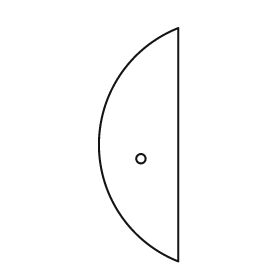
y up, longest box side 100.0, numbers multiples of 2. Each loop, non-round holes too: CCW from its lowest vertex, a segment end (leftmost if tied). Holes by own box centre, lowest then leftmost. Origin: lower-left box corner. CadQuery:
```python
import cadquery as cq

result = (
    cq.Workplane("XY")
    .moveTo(34.0, 0.0)
    .lineTo(34.0, 100.0)
    .threePointArc((0.0, 50.0), (34.0, 0.0))
    .close()
    .moveTo(18.0, 44.0)
    .circle(2.0)
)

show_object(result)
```